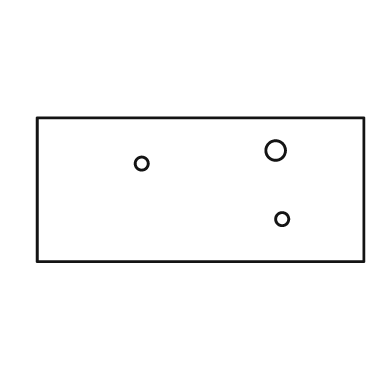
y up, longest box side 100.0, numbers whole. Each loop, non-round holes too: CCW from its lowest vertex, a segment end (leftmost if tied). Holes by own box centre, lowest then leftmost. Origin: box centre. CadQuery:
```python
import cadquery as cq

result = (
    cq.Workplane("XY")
    .moveTo(-50.0, -22.0)
    .lineTo(50.0, -22.0)
    .lineTo(50.0, 22.0)
    .lineTo(-50.0, 22.0)
    .close()
    .moveTo(25.0, -9.0)
    .circle(2.0)
    .moveTo(-18.0, 8.0)
    .circle(2.0)
    .moveTo(23.0, 12.0)
    .circle(3.0)
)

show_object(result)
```